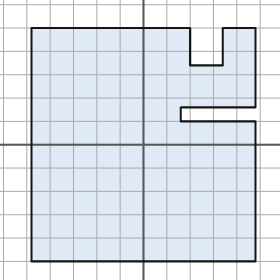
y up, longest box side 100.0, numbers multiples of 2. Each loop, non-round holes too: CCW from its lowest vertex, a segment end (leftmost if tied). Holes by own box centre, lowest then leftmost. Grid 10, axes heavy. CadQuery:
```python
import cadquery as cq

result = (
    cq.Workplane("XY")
    .moveTo(-48.0, -50.0)
    .lineTo(48.0, -50.0)
    .lineTo(48.0, 10.0)
    .lineTo(16.0, 10.0)
    .lineTo(16.0, 16.0)
    .lineTo(48.0, 16.0)
    .lineTo(48.0, 50.0)
    .lineTo(34.0, 50.0)
    .lineTo(34.0, 34.0)
    .lineTo(20.0, 34.0)
    .lineTo(20.0, 50.0)
    .lineTo(-48.0, 50.0)
    .close()
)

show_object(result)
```